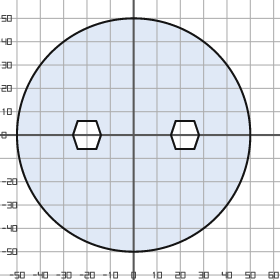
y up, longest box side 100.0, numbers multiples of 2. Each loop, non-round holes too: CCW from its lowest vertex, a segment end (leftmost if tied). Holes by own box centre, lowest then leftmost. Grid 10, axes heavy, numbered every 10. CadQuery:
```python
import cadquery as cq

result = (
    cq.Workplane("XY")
    .moveTo(0.0, 0.0)
    .circle(50.0)
    .moveTo(-24.0, -6.0)
    .lineTo(-16.0, -6.0)
    .lineTo(-14.0, 0.0)
    .lineTo(-16.0, 6.0)
    .lineTo(-24.0, 6.0)
    .lineTo(-26.0, 0.0)
    .close()
    .moveTo(18.0, -6.0)
    .lineTo(26.0, -6.0)
    .lineTo(28.0, 0.0)
    .lineTo(26.0, 6.0)
    .lineTo(18.0, 6.0)
    .lineTo(16.0, 0.0)
    .close()
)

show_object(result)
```